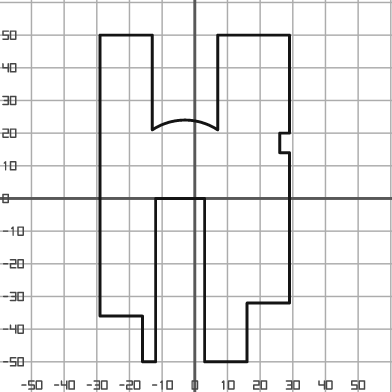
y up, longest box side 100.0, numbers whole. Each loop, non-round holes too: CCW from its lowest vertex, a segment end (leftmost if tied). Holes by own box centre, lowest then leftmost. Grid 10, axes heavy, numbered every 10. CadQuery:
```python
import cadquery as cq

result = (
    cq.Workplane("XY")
    .moveTo(-16.0, -50.0)
    .lineTo(-12.0, -50.0)
    .lineTo(-12.0, 0.0)
    .lineTo(3.0, 0.0)
    .lineTo(3.0, -50.0)
    .lineTo(16.0, -50.0)
    .lineTo(16.0, -32.0)
    .lineTo(29.0, -32.0)
    .lineTo(29.0, 14.0)
    .lineTo(26.0, 14.0)
    .lineTo(26.0, 20.0)
    .lineTo(29.0, 20.0)
    .lineTo(29.0, 50.0)
    .lineTo(7.0, 50.0)
    .lineTo(7.0, 21.0)
    .threePointArc((-3.0, 24.0), (-13.0, 21.0))
    .lineTo(-13.0, 50.0)
    .lineTo(-29.0, 50.0)
    .lineTo(-29.0, -36.0)
    .lineTo(-16.0, -36.0)
    .close()
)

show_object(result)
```